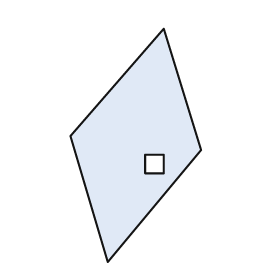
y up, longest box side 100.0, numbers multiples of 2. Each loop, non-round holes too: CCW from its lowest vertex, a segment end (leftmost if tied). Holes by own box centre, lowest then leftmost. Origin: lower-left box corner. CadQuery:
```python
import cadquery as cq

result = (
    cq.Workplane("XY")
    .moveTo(16.0, 0.0)
    .lineTo(56.0, 48.0)
    .lineTo(40.0, 100.0)
    .lineTo(0.0, 54.0)
    .close()
    .moveTo(32.0, 38.0)
    .lineTo(40.0, 38.0)
    .lineTo(40.0, 46.0)
    .lineTo(32.0, 46.0)
    .close()
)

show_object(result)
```